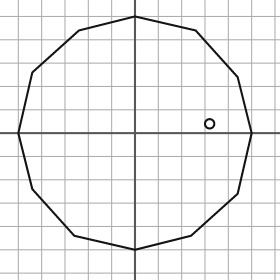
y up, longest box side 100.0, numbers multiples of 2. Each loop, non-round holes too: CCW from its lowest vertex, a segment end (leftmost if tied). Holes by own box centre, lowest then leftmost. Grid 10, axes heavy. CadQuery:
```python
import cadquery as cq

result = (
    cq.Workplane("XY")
    .moveTo(0.0, -50.0)
    .lineTo(24.0, -44.0)
    .lineTo(44.0, -26.0)
    .lineTo(50.0, 0.0)
    .lineTo(44.0, 24.0)
    .lineTo(26.0, 44.0)
    .lineTo(0.0, 50.0)
    .lineTo(-24.0, 44.0)
    .lineTo(-44.0, 26.0)
    .lineTo(-50.0, 0.0)
    .lineTo(-44.0, -24.0)
    .lineTo(-26.0, -44.0)
    .close()
    .moveTo(32.0, 4.0)
    .circle(2.0)
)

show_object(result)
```